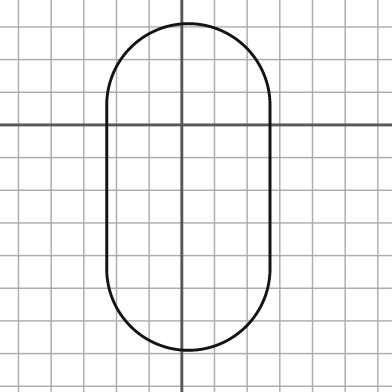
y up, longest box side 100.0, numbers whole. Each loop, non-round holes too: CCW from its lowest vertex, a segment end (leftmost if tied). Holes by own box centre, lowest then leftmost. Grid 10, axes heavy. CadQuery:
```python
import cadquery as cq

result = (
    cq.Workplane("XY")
    .moveTo(-23.0, -44.0)
    .threePointArc((2.0, -69.0), (27.0, -44.0))
    .lineTo(27.0, 6.0)
    .threePointArc((2.0, 31.0), (-23.0, 6.0))
    .close()
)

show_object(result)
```